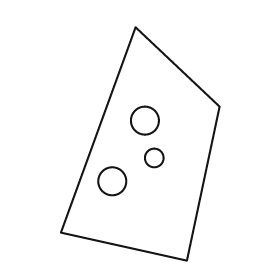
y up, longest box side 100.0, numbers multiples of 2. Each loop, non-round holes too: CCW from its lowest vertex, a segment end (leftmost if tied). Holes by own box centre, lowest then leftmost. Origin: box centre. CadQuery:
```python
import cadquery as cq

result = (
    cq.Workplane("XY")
    .moveTo(20.0, -50.0)
    .lineTo(34.0, 16.0)
    .lineTo(-2.0, 50.0)
    .lineTo(-34.0, -38.0)
    .close()
    .moveTo(-12.0, -16.0)
    .circle(6.0)
    .moveTo(6.0, -6.0)
    .circle(4.0)
    .moveTo(2.0, 10.0)
    .circle(6.0)
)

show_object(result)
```